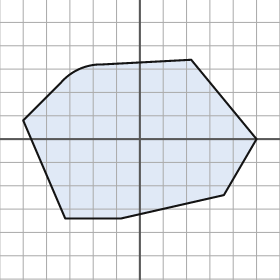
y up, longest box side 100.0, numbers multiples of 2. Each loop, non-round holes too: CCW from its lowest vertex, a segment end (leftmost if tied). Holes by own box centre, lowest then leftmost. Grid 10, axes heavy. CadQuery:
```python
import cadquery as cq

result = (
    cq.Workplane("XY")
    .moveTo(-32.0, -34.0)
    .lineTo(-8.0, -34.0)
    .lineTo(36.0, -24.0)
    .lineTo(50.0, 0.0)
    .lineTo(22.0, 34.0)
    .lineTo(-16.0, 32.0)
    .threePointArc((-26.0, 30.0), (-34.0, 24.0))
    .lineTo(-50.0, 8.0)
    .close()
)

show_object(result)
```